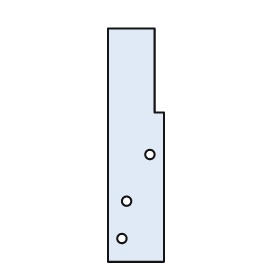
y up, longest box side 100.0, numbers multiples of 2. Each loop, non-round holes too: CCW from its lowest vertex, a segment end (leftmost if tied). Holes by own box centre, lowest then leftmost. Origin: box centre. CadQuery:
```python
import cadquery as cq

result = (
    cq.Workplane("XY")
    .moveTo(-12.0, -50.0)
    .lineTo(12.0, -50.0)
    .lineTo(12.0, 14.0)
    .lineTo(8.0, 14.0)
    .lineTo(8.0, 50.0)
    .lineTo(-12.0, 50.0)
    .close()
    .moveTo(-6.0, -40.0)
    .circle(2.0)
    .moveTo(-4.0, -24.0)
    .circle(2.0)
    .moveTo(6.0, -4.0)
    .circle(2.0)
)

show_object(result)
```